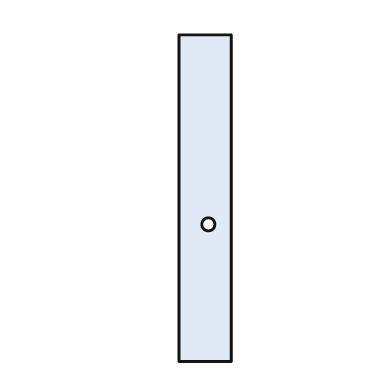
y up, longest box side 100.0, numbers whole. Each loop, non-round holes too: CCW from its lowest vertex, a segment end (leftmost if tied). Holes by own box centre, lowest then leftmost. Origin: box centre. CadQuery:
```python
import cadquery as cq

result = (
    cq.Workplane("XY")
    .moveTo(-8.0, -50.0)
    .lineTo(8.0, -50.0)
    .lineTo(8.0, 50.0)
    .lineTo(-8.0, 50.0)
    .close()
    .moveTo(1.0, -8.0)
    .circle(2.0)
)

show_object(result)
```